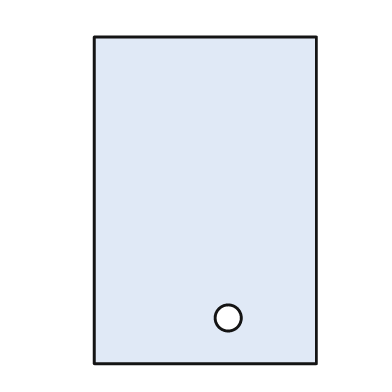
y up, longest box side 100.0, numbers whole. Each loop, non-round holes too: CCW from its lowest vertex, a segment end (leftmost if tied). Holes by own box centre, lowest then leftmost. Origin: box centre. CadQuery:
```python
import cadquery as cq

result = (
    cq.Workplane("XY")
    .moveTo(-34.0, -50.0)
    .lineTo(34.0, -50.0)
    .lineTo(34.0, 50.0)
    .lineTo(-34.0, 50.0)
    .close()
    .moveTo(7.0, -36.0)
    .circle(4.0)
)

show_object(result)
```